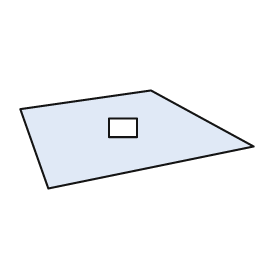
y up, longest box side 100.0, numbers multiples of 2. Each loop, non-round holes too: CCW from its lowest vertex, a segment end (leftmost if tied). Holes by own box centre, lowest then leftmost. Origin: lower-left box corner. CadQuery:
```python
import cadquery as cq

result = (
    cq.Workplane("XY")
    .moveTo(12.0, 0.0)
    .lineTo(100.0, 18.0)
    .lineTo(56.0, 42.0)
    .lineTo(0.0, 34.0)
    .close()
    .moveTo(38.0, 22.0)
    .lineTo(50.0, 22.0)
    .lineTo(50.0, 30.0)
    .lineTo(38.0, 30.0)
    .close()
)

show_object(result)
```